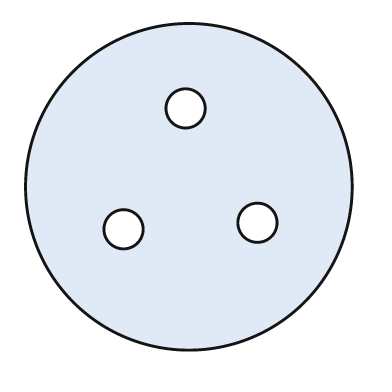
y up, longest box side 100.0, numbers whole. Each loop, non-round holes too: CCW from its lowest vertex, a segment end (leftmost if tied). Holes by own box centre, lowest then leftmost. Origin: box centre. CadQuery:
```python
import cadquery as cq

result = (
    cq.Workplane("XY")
    .moveTo(0.0, 0.0)
    .circle(50.0)
    .moveTo(-20.0, -13.0)
    .circle(6.0)
    .moveTo(21.0, -11.0)
    .circle(6.0)
    .moveTo(-1.0, 24.0)
    .circle(6.0)
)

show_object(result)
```